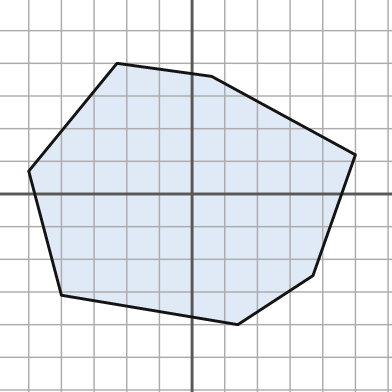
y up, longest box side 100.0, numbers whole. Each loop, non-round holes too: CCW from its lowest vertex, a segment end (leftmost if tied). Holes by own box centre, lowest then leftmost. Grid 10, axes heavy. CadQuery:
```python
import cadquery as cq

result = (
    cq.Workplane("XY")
    .moveTo(14.0, -40.0)
    .lineTo(37.0, -25.0)
    .lineTo(50.0, 12.0)
    .lineTo(6.0, 36.0)
    .lineTo(-23.0, 40.0)
    .lineTo(-50.0, 7.0)
    .lineTo(-40.0, -31.0)
    .close()
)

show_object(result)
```